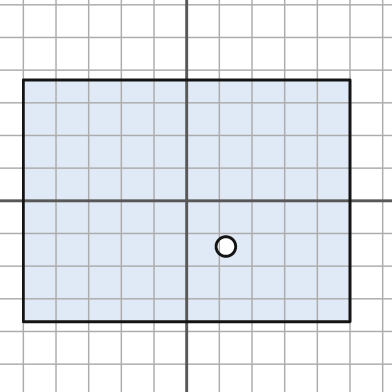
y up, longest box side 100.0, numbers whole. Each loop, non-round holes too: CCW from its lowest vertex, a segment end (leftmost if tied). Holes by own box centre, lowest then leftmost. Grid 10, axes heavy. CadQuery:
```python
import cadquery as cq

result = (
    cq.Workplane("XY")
    .moveTo(-50.0, -37.0)
    .lineTo(50.0, -37.0)
    .lineTo(50.0, 37.0)
    .lineTo(-50.0, 37.0)
    .close()
    .moveTo(12.0, -14.0)
    .circle(3.0)
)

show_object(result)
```